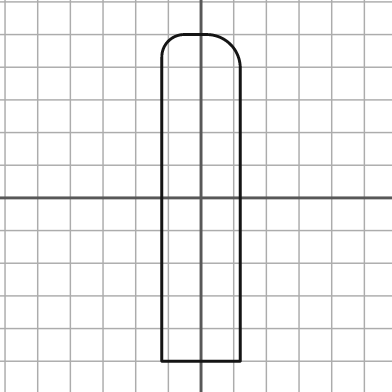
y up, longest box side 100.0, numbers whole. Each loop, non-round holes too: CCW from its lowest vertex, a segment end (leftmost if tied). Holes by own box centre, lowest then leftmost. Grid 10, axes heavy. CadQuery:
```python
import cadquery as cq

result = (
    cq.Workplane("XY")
    .moveTo(-12.0, -50.0)
    .lineTo(12.0, -50.0)
    .lineTo(12.0, 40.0)
    .threePointArc((9.0, 47.0), (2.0, 50.0))
    .lineTo(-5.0, 50.0)
    .threePointArc((-10.0, 48.0), (-12.0, 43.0))
    .close()
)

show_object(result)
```